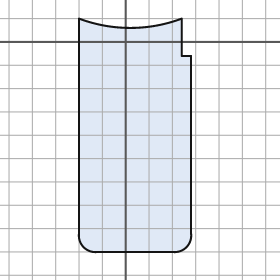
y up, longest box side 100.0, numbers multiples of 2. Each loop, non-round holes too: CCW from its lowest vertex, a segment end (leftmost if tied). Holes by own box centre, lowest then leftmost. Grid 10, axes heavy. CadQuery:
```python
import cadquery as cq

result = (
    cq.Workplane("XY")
    .moveTo(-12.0, -90.0)
    .lineTo(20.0, -90.0)
    .threePointArc((26.0, -88.0), (28.0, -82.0))
    .lineTo(28.0, -6.0)
    .lineTo(24.0, -6.0)
    .lineTo(24.0, 10.0)
    .threePointArc((2.0, 6.0), (-20.0, 10.0))
    .lineTo(-20.0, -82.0)
    .threePointArc((-18.0, -88.0), (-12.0, -90.0))
    .close()
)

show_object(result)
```